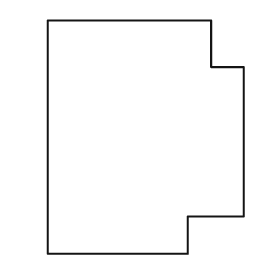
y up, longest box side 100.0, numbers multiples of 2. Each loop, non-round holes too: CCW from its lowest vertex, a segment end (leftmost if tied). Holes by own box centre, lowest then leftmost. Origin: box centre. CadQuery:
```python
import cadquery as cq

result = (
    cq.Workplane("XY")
    .moveTo(-42.0, -50.0)
    .lineTo(18.0, -50.0)
    .lineTo(18.0, -34.0)
    .lineTo(42.0, -34.0)
    .lineTo(42.0, 30.0)
    .lineTo(28.0, 30.0)
    .lineTo(28.0, 50.0)
    .lineTo(-42.0, 50.0)
    .close()
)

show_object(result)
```